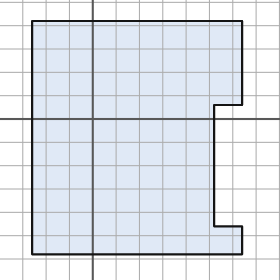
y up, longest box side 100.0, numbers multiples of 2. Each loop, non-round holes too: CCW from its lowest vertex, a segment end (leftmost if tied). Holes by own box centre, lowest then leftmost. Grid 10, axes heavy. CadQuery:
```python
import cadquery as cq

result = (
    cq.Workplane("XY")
    .moveTo(-26.0, -58.0)
    .lineTo(64.0, -58.0)
    .lineTo(64.0, -46.0)
    .lineTo(52.0, -46.0)
    .lineTo(52.0, 6.0)
    .lineTo(64.0, 6.0)
    .lineTo(64.0, 42.0)
    .lineTo(-26.0, 42.0)
    .close()
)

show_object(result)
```